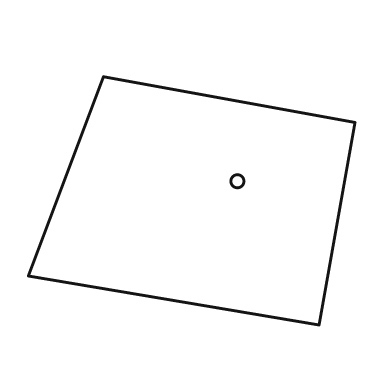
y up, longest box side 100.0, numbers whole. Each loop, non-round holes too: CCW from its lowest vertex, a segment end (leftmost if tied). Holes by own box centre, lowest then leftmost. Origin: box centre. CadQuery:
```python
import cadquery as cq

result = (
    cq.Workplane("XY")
    .moveTo(39.0, -38.0)
    .lineTo(50.0, 24.0)
    .lineTo(-27.0, 38.0)
    .lineTo(-50.0, -23.0)
    .close()
    .moveTo(14.0, 6.0)
    .circle(2.0)
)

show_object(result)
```